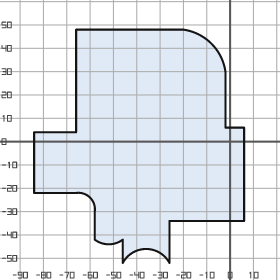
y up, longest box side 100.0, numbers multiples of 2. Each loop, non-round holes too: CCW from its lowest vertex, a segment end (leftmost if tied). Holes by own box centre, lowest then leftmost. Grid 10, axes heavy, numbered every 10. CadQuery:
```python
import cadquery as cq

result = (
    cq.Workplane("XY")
    .moveTo(-46.0, -52.0)
    .threePointArc((-36.0, -46.0), (-26.0, -52.0))
    .lineTo(-26.0, -34.0)
    .lineTo(6.0, -34.0)
    .lineTo(6.0, 6.0)
    .lineTo(-2.0, 6.0)
    .lineTo(-2.0, 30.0)
    .threePointArc((-8.0, 42.0), (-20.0, 48.0))
    .lineTo(-66.0, 48.0)
    .lineTo(-66.0, 4.0)
    .lineTo(-84.0, 4.0)
    .lineTo(-84.0, -22.0)
    .lineTo(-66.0, -22.0)
    .threePointArc((-60.0, -24.0), (-58.0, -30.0))
    .lineTo(-58.0, -42.0)
    .threePointArc((-52.0, -44.0), (-46.0, -42.0))
    .close()
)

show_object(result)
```